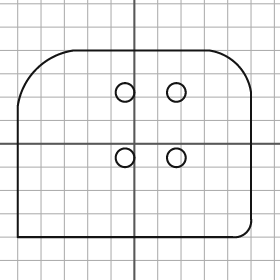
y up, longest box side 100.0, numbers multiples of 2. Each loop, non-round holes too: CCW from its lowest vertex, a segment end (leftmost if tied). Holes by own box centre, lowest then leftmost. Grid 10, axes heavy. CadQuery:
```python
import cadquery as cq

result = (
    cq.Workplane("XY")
    .moveTo(-50.0, -40.0)
    .lineTo(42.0, -40.0)
    .threePointArc((48.0, -38.0), (50.0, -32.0))
    .lineTo(50.0, 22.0)
    .threePointArc((44.0, 34.0), (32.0, 40.0))
    .lineTo(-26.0, 40.0)
    .threePointArc((-42.0, 32.0), (-50.0, 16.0))
    .close()
    .moveTo(-4.0, -6.0)
    .circle(4.0)
    .moveTo(18.0, -6.0)
    .circle(4.0)
    .moveTo(-4.0, 22.0)
    .circle(4.0)
    .moveTo(18.0, 22.0)
    .circle(4.0)
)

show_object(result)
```